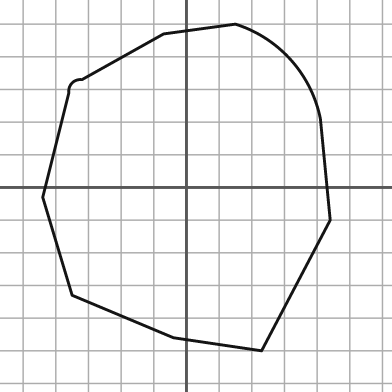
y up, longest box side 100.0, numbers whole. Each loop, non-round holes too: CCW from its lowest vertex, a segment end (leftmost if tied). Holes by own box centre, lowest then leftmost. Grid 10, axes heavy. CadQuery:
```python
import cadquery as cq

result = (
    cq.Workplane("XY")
    .moveTo(23.0, -50.0)
    .lineTo(44.0, -10.0)
    .lineTo(41.0, 21.0)
    .threePointArc((32.0, 39.0), (15.0, 50.0))
    .lineTo(-7.0, 47.0)
    .lineTo(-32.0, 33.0)
    .threePointArc((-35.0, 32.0), (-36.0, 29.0))
    .lineTo(-44.0, -3.0)
    .lineTo(-35.0, -33.0)
    .lineTo(-4.0, -46.0)
    .close()
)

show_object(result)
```